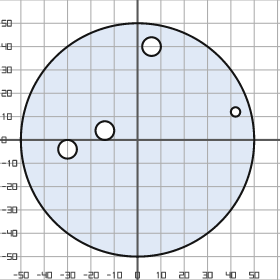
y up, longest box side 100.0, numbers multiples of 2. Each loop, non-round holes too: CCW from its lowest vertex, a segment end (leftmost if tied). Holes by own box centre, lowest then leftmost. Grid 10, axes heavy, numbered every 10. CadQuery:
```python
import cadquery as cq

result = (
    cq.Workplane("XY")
    .moveTo(0.0, 0.0)
    .circle(50.0)
    .moveTo(-30.0, -4.0)
    .circle(4.0)
    .moveTo(-14.0, 4.0)
    .circle(4.0)
    .moveTo(42.0, 12.0)
    .circle(2.0)
    .moveTo(6.0, 40.0)
    .circle(4.0)
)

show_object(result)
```